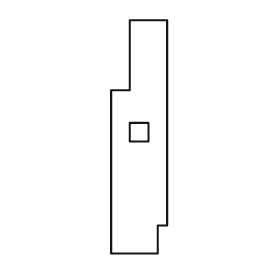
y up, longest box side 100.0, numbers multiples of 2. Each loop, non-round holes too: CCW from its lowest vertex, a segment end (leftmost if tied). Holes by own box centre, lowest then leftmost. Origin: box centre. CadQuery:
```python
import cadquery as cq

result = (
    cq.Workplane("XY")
    .moveTo(-12.0, -50.0)
    .lineTo(8.0, -50.0)
    .lineTo(8.0, -38.0)
    .lineTo(12.0, -38.0)
    .lineTo(12.0, 50.0)
    .lineTo(-4.0, 50.0)
    .lineTo(-4.0, 20.0)
    .lineTo(-12.0, 20.0)
    .close()
    .moveTo(-4.0, -2.0)
    .lineTo(4.0, -2.0)
    .lineTo(4.0, 6.0)
    .lineTo(-4.0, 6.0)
    .close()
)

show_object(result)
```